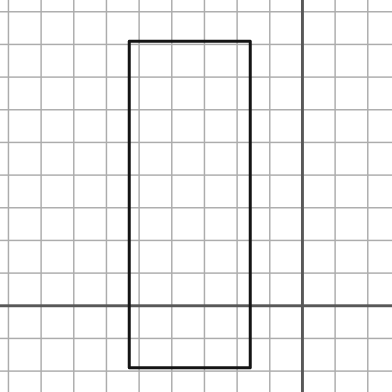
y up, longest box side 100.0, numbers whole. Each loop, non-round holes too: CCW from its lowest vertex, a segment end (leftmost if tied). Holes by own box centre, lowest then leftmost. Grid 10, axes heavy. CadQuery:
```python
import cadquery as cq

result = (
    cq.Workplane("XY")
    .moveTo(-53.0, -19.0)
    .lineTo(-16.0, -19.0)
    .lineTo(-16.0, 81.0)
    .lineTo(-53.0, 81.0)
    .close()
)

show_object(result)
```